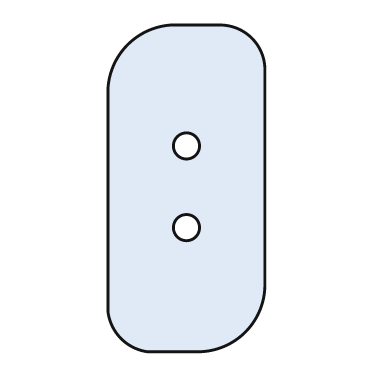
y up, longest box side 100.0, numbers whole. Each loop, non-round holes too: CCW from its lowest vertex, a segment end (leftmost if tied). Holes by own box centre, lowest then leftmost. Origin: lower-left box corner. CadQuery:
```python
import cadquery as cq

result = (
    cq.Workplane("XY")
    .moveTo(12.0, 0.0)
    .lineTo(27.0, 0.0)
    .threePointArc((42.0, 6.0), (48.0, 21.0))
    .lineTo(48.0, 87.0)
    .threePointArc((44.0, 96.0), (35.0, 100.0))
    .lineTo(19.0, 100.0)
    .threePointArc((6.0, 94.0), (0.0, 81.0))
    .lineTo(0.0, 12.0)
    .threePointArc((4.0, 4.0), (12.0, 0.0))
    .close()
    .moveTo(24.0, 38.0)
    .circle(4.0)
    .moveTo(24.0, 63.0)
    .circle(4.0)
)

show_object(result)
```